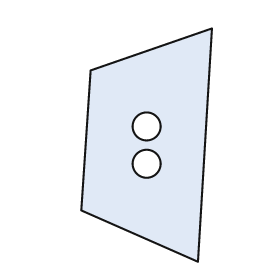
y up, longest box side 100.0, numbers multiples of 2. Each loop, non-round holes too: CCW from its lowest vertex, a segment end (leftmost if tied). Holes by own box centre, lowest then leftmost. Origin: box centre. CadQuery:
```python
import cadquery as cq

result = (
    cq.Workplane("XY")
    .moveTo(22.0, -50.0)
    .lineTo(28.0, 50.0)
    .lineTo(-24.0, 32.0)
    .lineTo(-28.0, -28.0)
    .close()
    .moveTo(0.0, -8.0)
    .circle(6.0)
    .moveTo(0.0, 8.0)
    .circle(6.0)
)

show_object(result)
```